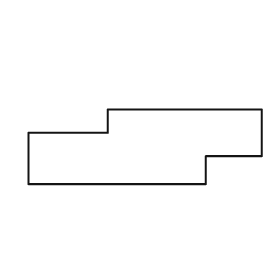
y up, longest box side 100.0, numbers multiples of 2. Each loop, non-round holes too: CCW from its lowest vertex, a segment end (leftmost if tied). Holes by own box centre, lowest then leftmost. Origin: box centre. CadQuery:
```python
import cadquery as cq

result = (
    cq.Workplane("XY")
    .moveTo(-50.0, -16.0)
    .lineTo(26.0, -16.0)
    .lineTo(26.0, -4.0)
    .lineTo(50.0, -4.0)
    .lineTo(50.0, 16.0)
    .lineTo(-16.0, 16.0)
    .lineTo(-16.0, 6.0)
    .lineTo(-50.0, 6.0)
    .close()
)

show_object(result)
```